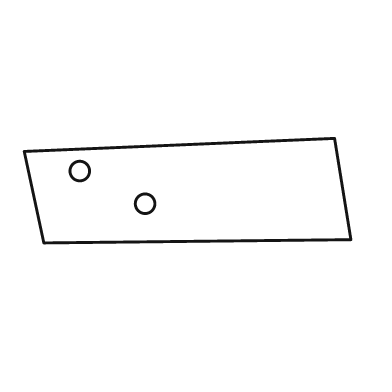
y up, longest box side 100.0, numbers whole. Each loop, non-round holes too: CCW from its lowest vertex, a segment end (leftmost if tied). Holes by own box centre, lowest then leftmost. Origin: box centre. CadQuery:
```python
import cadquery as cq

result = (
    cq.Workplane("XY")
    .moveTo(-44.0, -16.0)
    .lineTo(50.0, -15.0)
    .lineTo(45.0, 16.0)
    .lineTo(-50.0, 12.0)
    .close()
    .moveTo(-13.0, -4.0)
    .circle(3.0)
    .moveTo(-33.0, 6.0)
    .circle(3.0)
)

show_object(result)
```